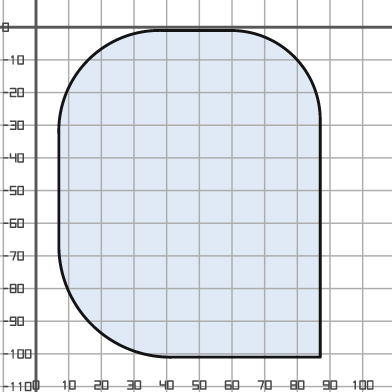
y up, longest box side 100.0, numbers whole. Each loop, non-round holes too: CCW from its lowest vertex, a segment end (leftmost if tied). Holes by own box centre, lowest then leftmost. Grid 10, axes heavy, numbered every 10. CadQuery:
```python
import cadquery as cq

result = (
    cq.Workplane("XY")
    .moveTo(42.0, -101.0)
    .lineTo(87.0, -101.0)
    .lineTo(87.0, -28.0)
    .threePointArc((79.0, -9.0), (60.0, -1.0))
    .lineTo(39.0, -1.0)
    .threePointArc((16.0, -10.0), (7.0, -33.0))
    .lineTo(7.0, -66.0)
    .threePointArc((17.0, -91.0), (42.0, -101.0))
    .close()
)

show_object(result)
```